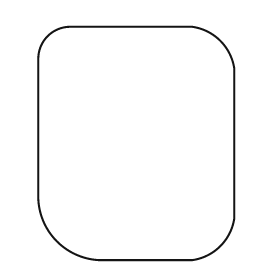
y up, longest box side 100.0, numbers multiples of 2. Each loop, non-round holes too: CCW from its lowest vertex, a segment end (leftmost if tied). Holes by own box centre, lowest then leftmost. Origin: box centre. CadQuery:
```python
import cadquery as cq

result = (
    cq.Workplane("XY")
    .moveTo(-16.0, -50.0)
    .lineTo(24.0, -50.0)
    .threePointArc((36.0, -44.0), (42.0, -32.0))
    .lineTo(42.0, 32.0)
    .threePointArc((36.0, 44.0), (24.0, 50.0))
    .lineTo(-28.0, 50.0)
    .threePointArc((-38.0, 46.0), (-42.0, 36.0))
    .lineTo(-42.0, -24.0)
    .threePointArc((-34.0, -42.0), (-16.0, -50.0))
    .close()
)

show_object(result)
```